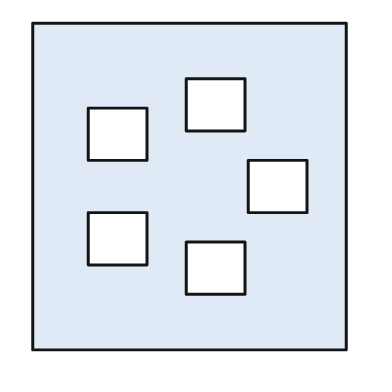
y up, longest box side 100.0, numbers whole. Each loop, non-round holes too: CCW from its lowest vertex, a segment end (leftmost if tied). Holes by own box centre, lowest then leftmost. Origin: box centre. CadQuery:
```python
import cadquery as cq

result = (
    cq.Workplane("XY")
    .moveTo(-48.0, -50.0)
    .lineTo(48.0, -50.0)
    .lineTo(48.0, 50.0)
    .lineTo(-48.0, 50.0)
    .close()
    .moveTo(-1.0, -33.0)
    .lineTo(17.0, -33.0)
    .lineTo(17.0, -17.0)
    .lineTo(-1.0, -17.0)
    .close()
    .moveTo(-31.0, -24.0)
    .lineTo(-13.0, -24.0)
    .lineTo(-13.0, -8.0)
    .lineTo(-31.0, -8.0)
    .close()
    .moveTo(18.0, -8.0)
    .lineTo(36.0, -8.0)
    .lineTo(36.0, 8.0)
    .lineTo(18.0, 8.0)
    .close()
    .moveTo(-31.0, 8.0)
    .lineTo(-13.0, 8.0)
    .lineTo(-13.0, 24.0)
    .lineTo(-31.0, 24.0)
    .close()
    .moveTo(-1.0, 17.0)
    .lineTo(17.0, 17.0)
    .lineTo(17.0, 33.0)
    .lineTo(-1.0, 33.0)
    .close()
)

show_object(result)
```